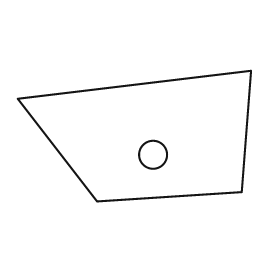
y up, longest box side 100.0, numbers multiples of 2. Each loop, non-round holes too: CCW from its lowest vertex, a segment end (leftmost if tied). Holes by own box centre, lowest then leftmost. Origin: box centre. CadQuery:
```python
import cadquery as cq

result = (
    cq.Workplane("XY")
    .moveTo(-16.0, -28.0)
    .lineTo(46.0, -24.0)
    .lineTo(50.0, 28.0)
    .lineTo(-50.0, 16.0)
    .close()
    .moveTo(8.0, -8.0)
    .circle(6.0)
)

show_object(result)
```